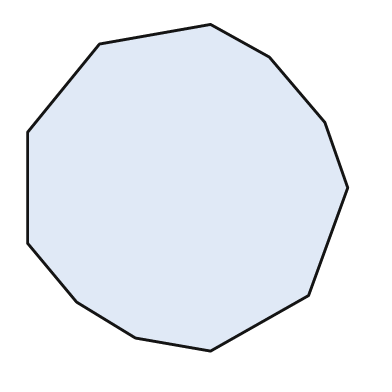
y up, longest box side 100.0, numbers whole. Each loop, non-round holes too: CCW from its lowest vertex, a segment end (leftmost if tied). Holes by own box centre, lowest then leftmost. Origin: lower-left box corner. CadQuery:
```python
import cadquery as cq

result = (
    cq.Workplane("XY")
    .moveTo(56.0, 0.0)
    .lineTo(86.0, 17.0)
    .lineTo(98.0, 50.0)
    .lineTo(91.0, 70.0)
    .lineTo(74.0, 90.0)
    .lineTo(56.0, 100.0)
    .lineTo(22.0, 94.0)
    .lineTo(0.0, 67.0)
    .lineTo(0.0, 33.0)
    .lineTo(15.0, 15.0)
    .lineTo(33.0, 4.0)
    .close()
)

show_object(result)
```